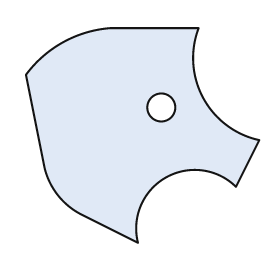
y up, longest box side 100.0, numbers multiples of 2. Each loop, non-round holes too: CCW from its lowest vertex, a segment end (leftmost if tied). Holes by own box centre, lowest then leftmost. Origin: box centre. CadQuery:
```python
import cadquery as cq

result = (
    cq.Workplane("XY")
    .moveTo(-2.0, -46.0)
    .threePointArc((10.0, -18.0), (40.0, -22.0))
    .lineTo(50.0, -2.0)
    .threePointArc((26.0, 16.0), (24.0, 46.0))
    .lineTo(-14.0, 46.0)
    .threePointArc((-34.0, 40.0), (-50.0, 26.0))
    .lineTo(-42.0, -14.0)
    .threePointArc((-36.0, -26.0), (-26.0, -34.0))
    .close()
    .moveTo(8.0, 12.0)
    .circle(6.0)
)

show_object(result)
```